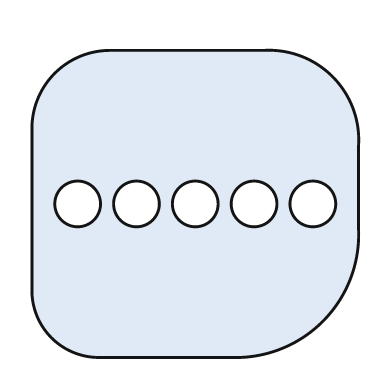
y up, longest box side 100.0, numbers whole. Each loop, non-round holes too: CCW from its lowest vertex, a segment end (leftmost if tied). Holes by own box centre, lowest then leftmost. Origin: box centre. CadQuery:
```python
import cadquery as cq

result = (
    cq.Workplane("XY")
    .moveTo(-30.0, -47.0)
    .lineTo(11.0, -47.0)
    .threePointArc((39.0, -36.0), (50.0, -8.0))
    .lineTo(50.0, 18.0)
    .threePointArc((42.0, 39.0), (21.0, 47.0))
    .lineTo(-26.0, 47.0)
    .threePointArc((-43.0, 40.0), (-50.0, 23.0))
    .lineTo(-50.0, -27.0)
    .threePointArc((-44.0, -41.0), (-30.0, -47.0))
    .close()
    .moveTo(-36.0, 0.0)
    .circle(7.0)
    .moveTo(-18.0, 0.0)
    .circle(7.0)
    .moveTo(0.0, 0.0)
    .circle(7.0)
    .moveTo(18.0, 0.0)
    .circle(7.0)
    .moveTo(36.0, 0.0)
    .circle(7.0)
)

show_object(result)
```